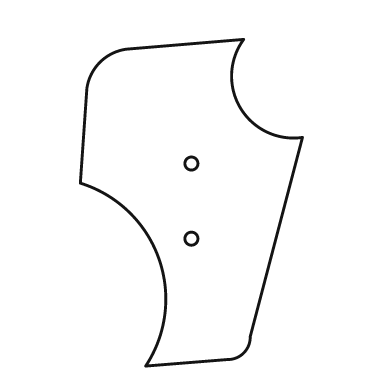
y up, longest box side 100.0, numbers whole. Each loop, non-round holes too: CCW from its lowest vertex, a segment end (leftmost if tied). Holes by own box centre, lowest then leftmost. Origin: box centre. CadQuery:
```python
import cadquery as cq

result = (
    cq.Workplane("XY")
    .moveTo(-14.0, -50.0)
    .lineTo(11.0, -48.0)
    .threePointArc((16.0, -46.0), (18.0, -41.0))
    .lineTo(34.0, 20.0)
    .threePointArc((15.0, 29.0), (16.0, 50.0))
    .lineTo(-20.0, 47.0)
    .threePointArc((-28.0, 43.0), (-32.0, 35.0))
    .lineTo(-34.0, 6.0)
    .threePointArc((-10.0, -17.0), (-14.0, -50.0))
    .close()
    .moveTo(0.0, -11.0)
    .circle(2.0)
    .moveTo(0.0, 12.0)
    .circle(2.0)
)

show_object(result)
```